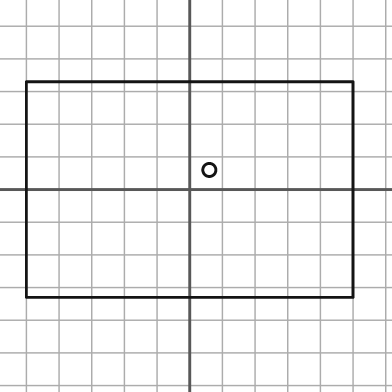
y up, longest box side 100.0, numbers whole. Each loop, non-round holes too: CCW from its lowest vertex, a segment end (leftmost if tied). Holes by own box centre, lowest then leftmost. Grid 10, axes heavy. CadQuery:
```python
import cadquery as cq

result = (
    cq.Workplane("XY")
    .moveTo(-50.0, -33.0)
    .lineTo(50.0, -33.0)
    .lineTo(50.0, 33.0)
    .lineTo(-50.0, 33.0)
    .close()
    .moveTo(6.0, 6.0)
    .circle(2.0)
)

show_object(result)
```